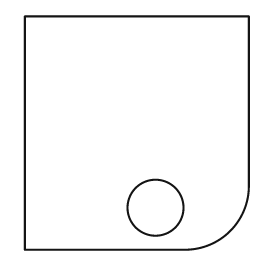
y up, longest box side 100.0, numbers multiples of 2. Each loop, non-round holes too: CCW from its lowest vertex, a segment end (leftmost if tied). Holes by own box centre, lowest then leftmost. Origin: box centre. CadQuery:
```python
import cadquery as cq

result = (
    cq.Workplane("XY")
    .moveTo(-48.0, -50.0)
    .lineTo(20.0, -50.0)
    .threePointArc((40.0, -42.0), (48.0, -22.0))
    .lineTo(48.0, 50.0)
    .lineTo(-48.0, 50.0)
    .close()
    .moveTo(8.0, -32.0)
    .circle(12.0)
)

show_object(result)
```